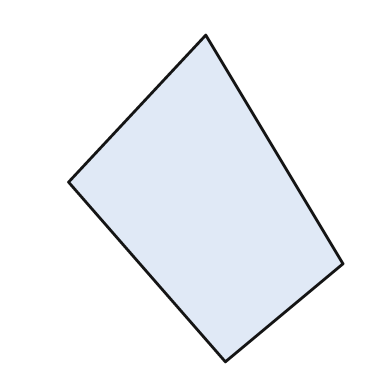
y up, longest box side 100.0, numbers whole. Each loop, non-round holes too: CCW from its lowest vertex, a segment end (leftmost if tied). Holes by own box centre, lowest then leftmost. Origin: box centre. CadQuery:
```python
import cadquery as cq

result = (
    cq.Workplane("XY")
    .moveTo(6.0, -50.0)
    .lineTo(42.0, -20.0)
    .lineTo(0.0, 50.0)
    .lineTo(-42.0, 5.0)
    .close()
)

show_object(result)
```